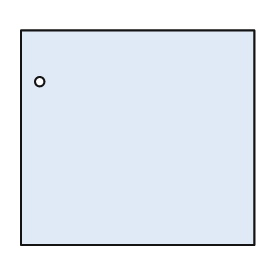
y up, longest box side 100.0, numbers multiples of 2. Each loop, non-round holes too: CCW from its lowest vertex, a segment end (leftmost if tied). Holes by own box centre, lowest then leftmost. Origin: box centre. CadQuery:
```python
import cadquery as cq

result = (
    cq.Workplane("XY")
    .moveTo(-50.0, -46.0)
    .lineTo(50.0, -46.0)
    .lineTo(50.0, 46.0)
    .lineTo(-50.0, 46.0)
    .close()
    .moveTo(-42.0, 24.0)
    .circle(2.0)
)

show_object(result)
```